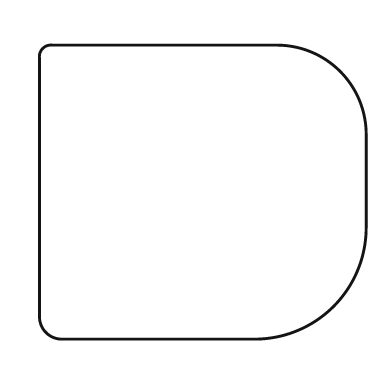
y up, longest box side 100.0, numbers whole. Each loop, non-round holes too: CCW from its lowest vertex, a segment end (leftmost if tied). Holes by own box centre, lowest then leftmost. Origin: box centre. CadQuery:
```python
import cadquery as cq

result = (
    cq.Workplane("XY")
    .moveTo(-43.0, -45.0)
    .lineTo(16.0, -45.0)
    .threePointArc((40.0, -35.0), (50.0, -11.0))
    .lineTo(50.0, 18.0)
    .threePointArc((42.0, 37.0), (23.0, 45.0))
    .lineTo(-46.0, 45.0)
    .threePointArc((-49.0, 44.0), (-50.0, 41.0))
    .lineTo(-50.0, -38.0)
    .threePointArc((-48.0, -43.0), (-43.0, -45.0))
    .close()
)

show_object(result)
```